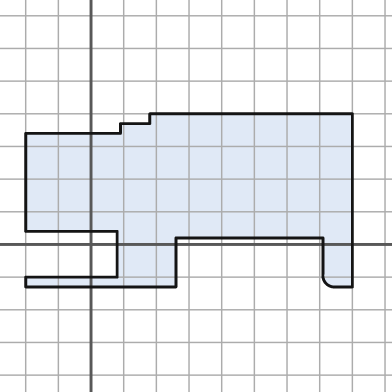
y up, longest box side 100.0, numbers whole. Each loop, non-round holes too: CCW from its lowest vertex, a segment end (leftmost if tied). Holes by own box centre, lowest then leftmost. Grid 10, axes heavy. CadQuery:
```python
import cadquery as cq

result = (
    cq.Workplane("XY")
    .moveTo(-20.0, -13.0)
    .lineTo(26.0, -13.0)
    .lineTo(26.0, 2.0)
    .lineTo(71.0, 2.0)
    .lineTo(71.0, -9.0)
    .threePointArc((72.0, -12.0), (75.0, -13.0))
    .lineTo(80.0, -13.0)
    .lineTo(80.0, 40.0)
    .lineTo(18.0, 40.0)
    .lineTo(18.0, 37.0)
    .lineTo(9.0, 37.0)
    .lineTo(9.0, 34.0)
    .lineTo(-20.0, 34.0)
    .lineTo(-20.0, 4.0)
    .lineTo(8.0, 4.0)
    .lineTo(8.0, -10.0)
    .lineTo(-20.0, -10.0)
    .close()
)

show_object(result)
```